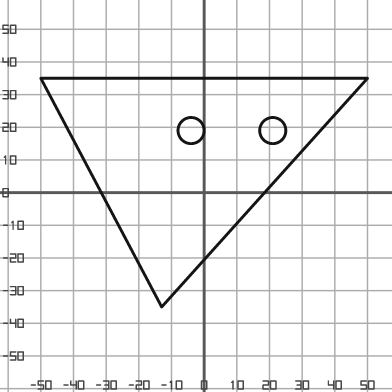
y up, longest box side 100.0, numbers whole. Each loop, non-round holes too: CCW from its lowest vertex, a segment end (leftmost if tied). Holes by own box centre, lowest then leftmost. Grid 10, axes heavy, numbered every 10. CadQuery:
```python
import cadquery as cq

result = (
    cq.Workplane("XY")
    .moveTo(-13.0, -35.0)
    .lineTo(50.0, 35.0)
    .lineTo(-50.0, 35.0)
    .close()
    .moveTo(-4.0, 19.0)
    .circle(4.0)
    .moveTo(21.0, 19.0)
    .circle(4.0)
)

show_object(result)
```